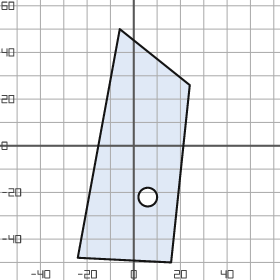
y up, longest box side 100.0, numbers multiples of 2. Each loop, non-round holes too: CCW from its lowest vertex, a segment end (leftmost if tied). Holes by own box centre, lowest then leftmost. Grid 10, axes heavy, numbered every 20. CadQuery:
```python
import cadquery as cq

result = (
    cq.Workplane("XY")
    .moveTo(16.0, -50.0)
    .lineTo(24.0, 26.0)
    .lineTo(-6.0, 50.0)
    .lineTo(-24.0, -48.0)
    .close()
    .moveTo(6.0, -22.0)
    .circle(4.0)
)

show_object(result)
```